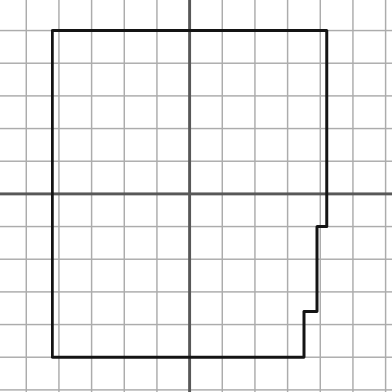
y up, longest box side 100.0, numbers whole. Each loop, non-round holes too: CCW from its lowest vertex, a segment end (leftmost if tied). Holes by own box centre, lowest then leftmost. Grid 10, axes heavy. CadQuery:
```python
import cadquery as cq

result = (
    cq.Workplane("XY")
    .moveTo(-42.0, -50.0)
    .lineTo(35.0, -50.0)
    .lineTo(35.0, -36.0)
    .lineTo(39.0, -36.0)
    .lineTo(39.0, -10.0)
    .lineTo(42.0, -10.0)
    .lineTo(42.0, 50.0)
    .lineTo(-42.0, 50.0)
    .close()
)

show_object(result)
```